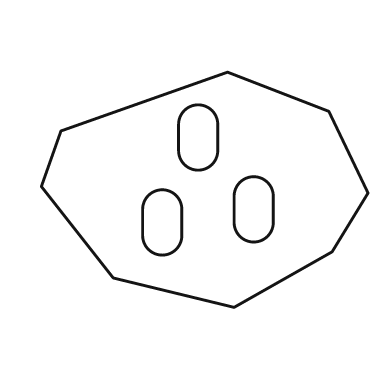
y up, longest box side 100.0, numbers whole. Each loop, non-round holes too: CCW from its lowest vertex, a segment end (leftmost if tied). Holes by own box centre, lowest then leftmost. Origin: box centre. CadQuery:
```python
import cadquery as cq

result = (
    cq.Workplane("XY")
    .moveTo(9.0, -36.0)
    .lineTo(39.0, -19.0)
    .lineTo(50.0, -1.0)
    .lineTo(38.0, 24.0)
    .lineTo(7.0, 36.0)
    .lineTo(-44.0, 18.0)
    .lineTo(-50.0, 1.0)
    .lineTo(-28.0, -27.0)
    .close()
    .moveTo(-19.0, -14.0)
    .threePointArc((-13.0, -20.0), (-7.0, -14.0))
    .lineTo(-7.0, -6.0)
    .threePointArc((-13.0, 0.0), (-19.0, -6.0))
    .close()
    .moveTo(9.0, -10.0)
    .threePointArc((15.0, -16.0), (21.0, -10.0))
    .lineTo(21.0, -2.0)
    .threePointArc((15.0, 4.0), (9.0, -2.0))
    .close()
    .moveTo(-8.0, 12.0)
    .threePointArc((-2.0, 6.0), (4.0, 12.0))
    .lineTo(4.0, 20.0)
    .threePointArc((-2.0, 26.0), (-8.0, 20.0))
    .close()
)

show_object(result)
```